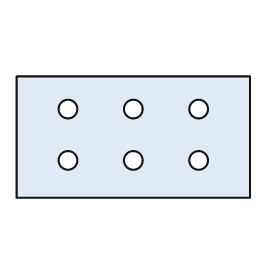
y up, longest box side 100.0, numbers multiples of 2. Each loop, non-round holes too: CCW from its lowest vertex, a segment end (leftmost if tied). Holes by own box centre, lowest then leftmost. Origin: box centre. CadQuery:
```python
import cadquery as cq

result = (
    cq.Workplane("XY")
    .moveTo(-50.0, -26.0)
    .lineTo(50.0, -26.0)
    .lineTo(50.0, 26.0)
    .lineTo(-50.0, 26.0)
    .close()
    .moveTo(-28.0, -10.0)
    .circle(4.0)
    .moveTo(0.0, -10.0)
    .circle(4.0)
    .moveTo(28.0, -10.0)
    .circle(4.0)
    .moveTo(-28.0, 12.0)
    .circle(4.0)
    .moveTo(0.0, 12.0)
    .circle(4.0)
    .moveTo(28.0, 12.0)
    .circle(4.0)
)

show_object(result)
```